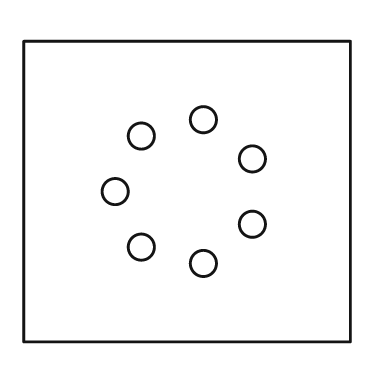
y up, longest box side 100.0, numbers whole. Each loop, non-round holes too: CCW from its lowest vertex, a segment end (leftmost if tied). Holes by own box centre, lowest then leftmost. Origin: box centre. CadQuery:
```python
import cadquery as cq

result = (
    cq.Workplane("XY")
    .moveTo(-50.0, -46.0)
    .lineTo(50.0, -46.0)
    .lineTo(50.0, 46.0)
    .lineTo(-50.0, 46.0)
    .close()
    .moveTo(5.0, -22.0)
    .circle(4.0)
    .moveTo(-14.0, -17.0)
    .circle(4.0)
    .moveTo(20.0, -10.0)
    .circle(4.0)
    .moveTo(-22.0, 0.0)
    .circle(4.0)
    .moveTo(20.0, 10.0)
    .circle(4.0)
    .moveTo(-14.0, 17.0)
    .circle(4.0)
    .moveTo(5.0, 22.0)
    .circle(4.0)
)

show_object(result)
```